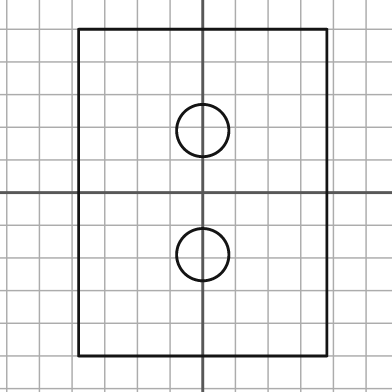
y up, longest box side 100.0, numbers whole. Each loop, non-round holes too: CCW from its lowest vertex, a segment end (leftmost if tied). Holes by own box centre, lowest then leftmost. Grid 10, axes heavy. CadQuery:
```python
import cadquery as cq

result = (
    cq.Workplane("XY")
    .moveTo(-38.0, -50.0)
    .lineTo(38.0, -50.0)
    .lineTo(38.0, 50.0)
    .lineTo(-38.0, 50.0)
    .close()
    .moveTo(0.0, -19.0)
    .circle(8.0)
    .moveTo(0.0, 19.0)
    .circle(8.0)
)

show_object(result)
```